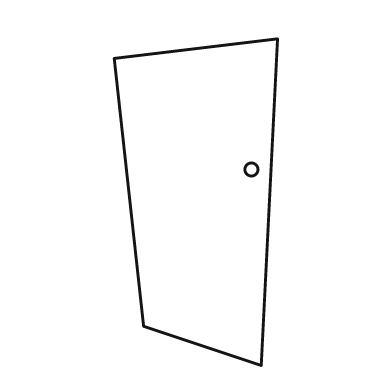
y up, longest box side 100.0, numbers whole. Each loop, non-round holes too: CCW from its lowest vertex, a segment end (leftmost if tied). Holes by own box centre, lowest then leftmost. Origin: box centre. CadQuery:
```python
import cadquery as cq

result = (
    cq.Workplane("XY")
    .moveTo(20.0, -50.0)
    .lineTo(25.0, 50.0)
    .lineTo(-25.0, 44.0)
    .lineTo(-16.0, -38.0)
    .close()
    .moveTo(17.0, 10.0)
    .circle(2.0)
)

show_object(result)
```